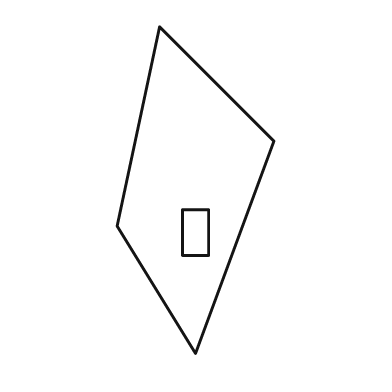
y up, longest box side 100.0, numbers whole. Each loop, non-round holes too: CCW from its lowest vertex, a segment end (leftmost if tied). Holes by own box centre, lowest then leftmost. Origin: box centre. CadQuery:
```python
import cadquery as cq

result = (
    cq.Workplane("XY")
    .moveTo(0.0, -50.0)
    .lineTo(24.0, 15.0)
    .lineTo(-11.0, 50.0)
    .lineTo(-24.0, -11.0)
    .close()
    .moveTo(-4.0, -20.0)
    .lineTo(4.0, -20.0)
    .lineTo(4.0, -6.0)
    .lineTo(-4.0, -6.0)
    .close()
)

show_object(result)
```